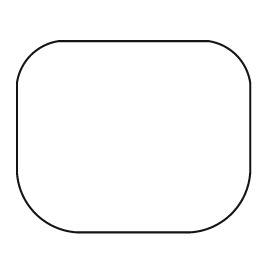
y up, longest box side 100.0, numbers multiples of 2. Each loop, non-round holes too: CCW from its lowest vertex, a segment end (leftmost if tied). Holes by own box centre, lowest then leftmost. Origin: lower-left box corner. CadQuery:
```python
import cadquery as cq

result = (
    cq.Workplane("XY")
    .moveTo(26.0, 0.0)
    .lineTo(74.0, 0.0)
    .threePointArc((92.0, 8.0), (100.0, 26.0))
    .lineTo(100.0, 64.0)
    .threePointArc((94.0, 76.0), (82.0, 82.0))
    .lineTo(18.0, 82.0)
    .threePointArc((6.0, 76.0), (0.0, 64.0))
    .lineTo(0.0, 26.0)
    .threePointArc((8.0, 8.0), (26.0, 0.0))
    .close()
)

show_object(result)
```